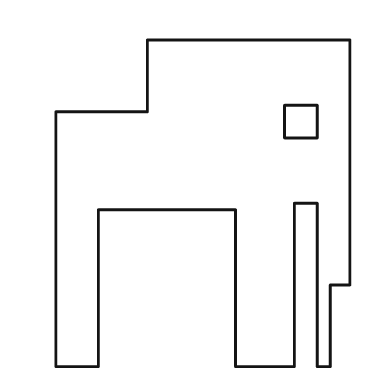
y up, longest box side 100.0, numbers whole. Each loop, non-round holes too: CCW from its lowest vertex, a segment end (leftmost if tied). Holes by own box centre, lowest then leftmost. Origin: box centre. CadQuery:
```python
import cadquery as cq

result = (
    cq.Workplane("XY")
    .moveTo(-45.0, -50.0)
    .lineTo(-32.0, -50.0)
    .lineTo(-32.0, -2.0)
    .lineTo(10.0, -2.0)
    .lineTo(10.0, -50.0)
    .lineTo(28.0, -50.0)
    .lineTo(28.0, 0.0)
    .lineTo(35.0, 0.0)
    .lineTo(35.0, -50.0)
    .lineTo(39.0, -50.0)
    .lineTo(39.0, -25.0)
    .lineTo(45.0, -25.0)
    .lineTo(45.0, 50.0)
    .lineTo(-17.0, 50.0)
    .lineTo(-17.0, 28.0)
    .lineTo(-45.0, 28.0)
    .close()
    .moveTo(25.0, 20.0)
    .lineTo(35.0, 20.0)
    .lineTo(35.0, 30.0)
    .lineTo(25.0, 30.0)
    .close()
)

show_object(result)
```